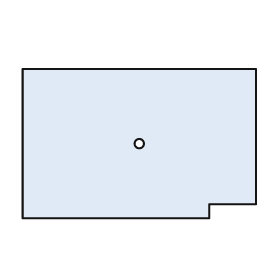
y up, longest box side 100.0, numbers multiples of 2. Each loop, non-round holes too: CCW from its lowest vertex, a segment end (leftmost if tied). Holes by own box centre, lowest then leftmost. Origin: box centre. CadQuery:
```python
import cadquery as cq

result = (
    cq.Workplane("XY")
    .moveTo(-50.0, -32.0)
    .lineTo(30.0, -32.0)
    .lineTo(30.0, -26.0)
    .lineTo(50.0, -26.0)
    .lineTo(50.0, 32.0)
    .lineTo(-50.0, 32.0)
    .close()
    .moveTo(0.0, 0.0)
    .circle(2.0)
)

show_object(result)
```